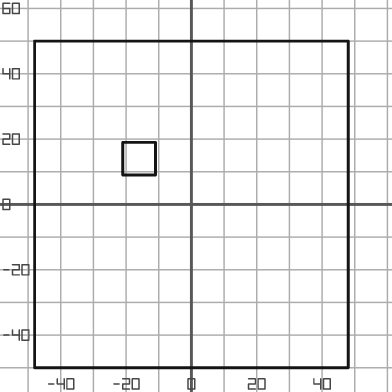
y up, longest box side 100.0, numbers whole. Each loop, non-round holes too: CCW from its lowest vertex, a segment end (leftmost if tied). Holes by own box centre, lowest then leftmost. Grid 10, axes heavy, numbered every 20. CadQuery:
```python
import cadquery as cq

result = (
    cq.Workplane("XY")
    .moveTo(-48.0, -50.0)
    .lineTo(48.0, -50.0)
    .lineTo(48.0, 50.0)
    .lineTo(-48.0, 50.0)
    .close()
    .moveTo(-21.0, 9.0)
    .lineTo(-11.0, 9.0)
    .lineTo(-11.0, 19.0)
    .lineTo(-21.0, 19.0)
    .close()
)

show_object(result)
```